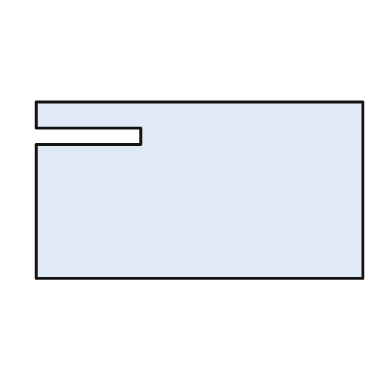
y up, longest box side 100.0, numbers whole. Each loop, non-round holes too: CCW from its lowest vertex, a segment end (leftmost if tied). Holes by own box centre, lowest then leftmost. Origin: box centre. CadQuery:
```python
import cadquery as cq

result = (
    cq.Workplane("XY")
    .moveTo(-50.0, -27.0)
    .lineTo(50.0, -27.0)
    .lineTo(50.0, 27.0)
    .lineTo(-50.0, 27.0)
    .lineTo(-50.0, 19.0)
    .lineTo(-18.0, 19.0)
    .lineTo(-18.0, 14.0)
    .lineTo(-50.0, 14.0)
    .close()
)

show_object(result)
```